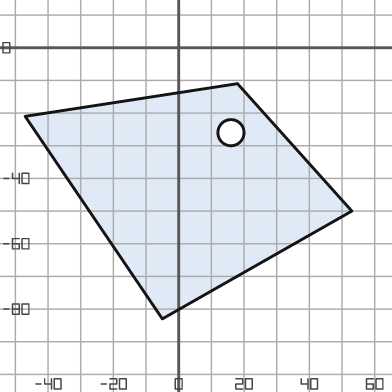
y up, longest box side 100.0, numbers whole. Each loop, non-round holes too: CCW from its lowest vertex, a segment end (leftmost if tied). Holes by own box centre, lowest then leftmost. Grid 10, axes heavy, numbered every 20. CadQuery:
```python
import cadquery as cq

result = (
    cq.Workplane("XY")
    .moveTo(-5.0, -83.0)
    .lineTo(53.0, -50.0)
    .lineTo(18.0, -11.0)
    .lineTo(-47.0, -21.0)
    .close()
    .moveTo(16.0, -26.0)
    .circle(4.0)
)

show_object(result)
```